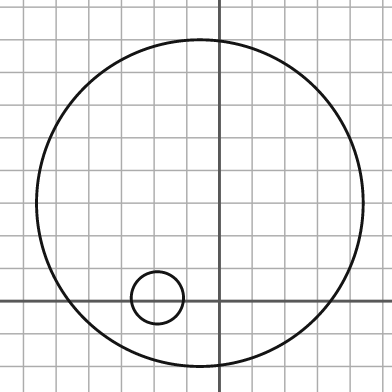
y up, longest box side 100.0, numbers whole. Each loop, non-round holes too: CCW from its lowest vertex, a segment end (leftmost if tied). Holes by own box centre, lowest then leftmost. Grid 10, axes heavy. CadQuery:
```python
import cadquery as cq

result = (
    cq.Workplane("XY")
    .moveTo(-6.0, 30.0)
    .circle(50.0)
    .moveTo(-19.0, 1.0)
    .circle(8.0)
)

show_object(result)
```